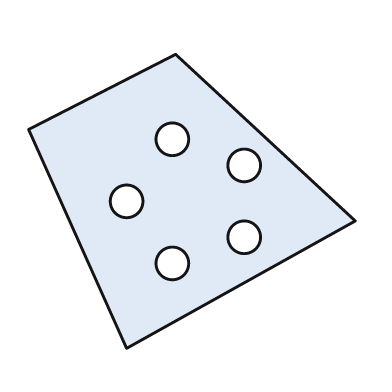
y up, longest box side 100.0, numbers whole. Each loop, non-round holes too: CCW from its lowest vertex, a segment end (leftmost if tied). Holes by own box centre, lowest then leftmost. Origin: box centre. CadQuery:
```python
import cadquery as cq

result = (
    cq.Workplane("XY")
    .moveTo(-20.0, -45.0)
    .lineTo(50.0, -6.0)
    .lineTo(-5.0, 45.0)
    .lineTo(-50.0, 22.0)
    .close()
    .moveTo(-6.0, -19.0)
    .circle(5.0)
    .moveTo(16.0, -11.0)
    .circle(5.0)
    .moveTo(-20.0, 0.0)
    .circle(5.0)
    .moveTo(16.0, 11.0)
    .circle(5.0)
    .moveTo(-6.0, 19.0)
    .circle(5.0)
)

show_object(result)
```